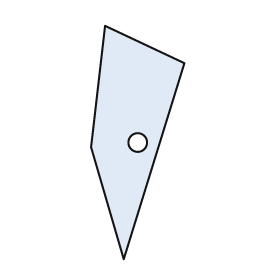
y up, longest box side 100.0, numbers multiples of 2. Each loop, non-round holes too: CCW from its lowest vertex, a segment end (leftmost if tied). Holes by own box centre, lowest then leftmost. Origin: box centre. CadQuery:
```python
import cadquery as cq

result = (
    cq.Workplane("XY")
    .moveTo(-6.0, -50.0)
    .lineTo(20.0, 34.0)
    .lineTo(-14.0, 50.0)
    .lineTo(-20.0, -2.0)
    .close()
    .moveTo(0.0, 0.0)
    .circle(4.0)
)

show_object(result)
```